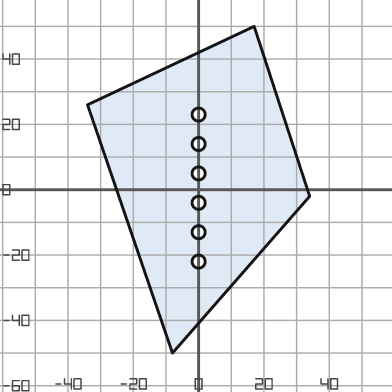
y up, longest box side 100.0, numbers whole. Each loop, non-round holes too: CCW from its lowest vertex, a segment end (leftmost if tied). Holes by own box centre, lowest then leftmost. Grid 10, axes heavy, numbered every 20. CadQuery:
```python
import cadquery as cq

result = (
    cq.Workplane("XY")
    .moveTo(-8.0, -50.0)
    .lineTo(34.0, -2.0)
    .lineTo(17.0, 50.0)
    .lineTo(-34.0, 26.0)
    .close()
    .moveTo(0.0, -22.0)
    .circle(2.0)
    .moveTo(0.0, -13.0)
    .circle(2.0)
    .moveTo(0.0, -4.0)
    .circle(2.0)
    .moveTo(0.0, 5.0)
    .circle(2.0)
    .moveTo(0.0, 14.0)
    .circle(2.0)
    .moveTo(0.0, 23.0)
    .circle(2.0)
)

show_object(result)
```